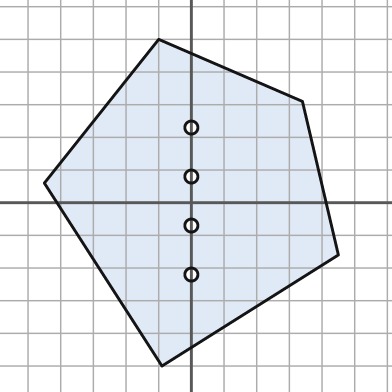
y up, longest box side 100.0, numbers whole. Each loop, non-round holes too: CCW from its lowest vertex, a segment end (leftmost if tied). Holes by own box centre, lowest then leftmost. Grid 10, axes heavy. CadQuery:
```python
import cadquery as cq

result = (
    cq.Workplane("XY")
    .moveTo(-9.0, -50.0)
    .lineTo(45.0, -16.0)
    .lineTo(34.0, 31.0)
    .lineTo(-10.0, 50.0)
    .lineTo(-45.0, 6.0)
    .close()
    .moveTo(0.0, -22.0)
    .circle(2.0)
    .moveTo(0.0, -7.0)
    .circle(2.0)
    .moveTo(0.0, 8.0)
    .circle(2.0)
    .moveTo(0.0, 23.0)
    .circle(2.0)
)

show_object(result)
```